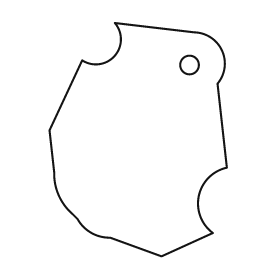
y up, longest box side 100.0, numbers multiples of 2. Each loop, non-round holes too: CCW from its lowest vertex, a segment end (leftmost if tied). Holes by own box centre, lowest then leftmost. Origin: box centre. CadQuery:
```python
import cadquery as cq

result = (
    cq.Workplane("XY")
    .moveTo(10.0, -50.0)
    .lineTo(32.0, -40.0)
    .threePointArc((26.0, -24.0), (38.0, -12.0))
    .lineTo(34.0, 24.0)
    .threePointArc((36.0, 38.0), (24.0, 46.0))
    .lineTo(-10.0, 50.0)
    .threePointArc((-10.0, 36.0), (-24.0, 34.0))
    .lineTo(-38.0, 4.0)
    .lineTo(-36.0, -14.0)
    .threePointArc((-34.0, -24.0), (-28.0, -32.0))
    .lineTo(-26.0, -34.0)
    .threePointArc((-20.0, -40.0), (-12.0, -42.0))
    .close()
    .moveTo(22.0, 32.0)
    .circle(4.0)
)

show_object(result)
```